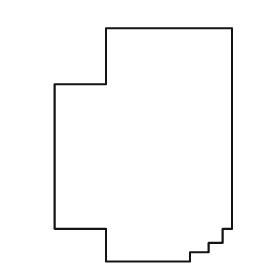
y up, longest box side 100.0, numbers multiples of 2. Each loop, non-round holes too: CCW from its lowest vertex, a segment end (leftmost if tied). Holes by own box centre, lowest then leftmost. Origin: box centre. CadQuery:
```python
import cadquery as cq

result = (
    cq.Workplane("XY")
    .moveTo(-16.0, -50.0)
    .lineTo(20.0, -50.0)
    .lineTo(20.0, -46.0)
    .lineTo(28.0, -46.0)
    .lineTo(28.0, -42.0)
    .lineTo(34.0, -42.0)
    .lineTo(34.0, -36.0)
    .lineTo(38.0, -36.0)
    .lineTo(38.0, 50.0)
    .lineTo(-16.0, 50.0)
    .lineTo(-16.0, 26.0)
    .lineTo(-38.0, 26.0)
    .lineTo(-38.0, -36.0)
    .lineTo(-16.0, -36.0)
    .close()
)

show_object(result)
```